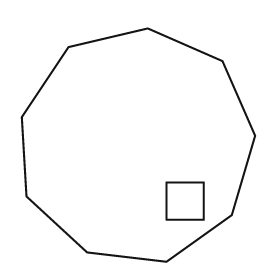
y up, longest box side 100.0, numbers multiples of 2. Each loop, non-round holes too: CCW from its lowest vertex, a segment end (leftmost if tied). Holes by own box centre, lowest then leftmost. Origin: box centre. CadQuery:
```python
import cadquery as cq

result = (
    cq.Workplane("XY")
    .moveTo(12.0, -50.0)
    .lineTo(40.0, -30.0)
    .lineTo(50.0, 4.0)
    .lineTo(36.0, 36.0)
    .lineTo(4.0, 50.0)
    .lineTo(-30.0, 42.0)
    .lineTo(-50.0, 12.0)
    .lineTo(-48.0, -22.0)
    .lineTo(-22.0, -46.0)
    .close()
    .moveTo(12.0, -32.0)
    .lineTo(28.0, -32.0)
    .lineTo(28.0, -16.0)
    .lineTo(12.0, -16.0)
    .close()
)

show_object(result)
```